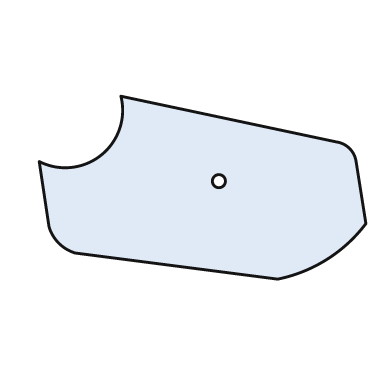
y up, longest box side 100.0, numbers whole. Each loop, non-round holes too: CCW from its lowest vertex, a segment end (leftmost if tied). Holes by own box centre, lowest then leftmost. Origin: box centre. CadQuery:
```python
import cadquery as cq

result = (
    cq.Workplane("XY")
    .moveTo(23.0, -28.0)
    .threePointArc((38.0, -22.0), (50.0, -11.0))
    .lineTo(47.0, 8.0)
    .threePointArc((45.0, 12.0), (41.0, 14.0))
    .lineTo(-25.0, 28.0)
    .threePointArc((-31.0, 10.0), (-50.0, 8.0))
    .lineTo(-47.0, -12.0)
    .threePointArc((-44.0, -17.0), (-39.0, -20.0))
    .close()
    .moveTo(5.0, 2.0)
    .circle(2.0)
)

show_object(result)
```